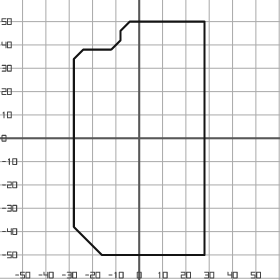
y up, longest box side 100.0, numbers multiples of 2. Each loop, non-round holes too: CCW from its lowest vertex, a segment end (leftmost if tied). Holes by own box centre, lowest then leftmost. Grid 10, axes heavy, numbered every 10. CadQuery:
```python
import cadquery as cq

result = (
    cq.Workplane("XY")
    .moveTo(-16.0, -50.0)
    .lineTo(28.0, -50.0)
    .lineTo(28.0, 50.0)
    .lineTo(-4.0, 50.0)
    .lineTo(-8.0, 46.0)
    .lineTo(-8.0, 42.0)
    .lineTo(-12.0, 38.0)
    .lineTo(-24.0, 38.0)
    .lineTo(-28.0, 34.0)
    .lineTo(-28.0, -38.0)
    .close()
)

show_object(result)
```